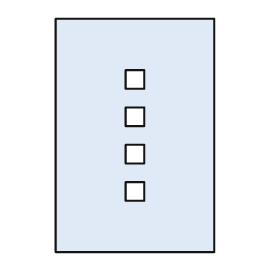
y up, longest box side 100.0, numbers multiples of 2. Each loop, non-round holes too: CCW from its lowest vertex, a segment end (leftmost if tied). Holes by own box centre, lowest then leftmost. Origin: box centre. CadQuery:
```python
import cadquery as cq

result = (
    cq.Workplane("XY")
    .moveTo(-34.0, -50.0)
    .lineTo(34.0, -50.0)
    .lineTo(34.0, 50.0)
    .lineTo(-34.0, 50.0)
    .close()
    .moveTo(-4.0, -28.0)
    .lineTo(4.0, -28.0)
    .lineTo(4.0, -20.0)
    .lineTo(-4.0, -20.0)
    .close()
    .moveTo(-4.0, -12.0)
    .lineTo(4.0, -12.0)
    .lineTo(4.0, -4.0)
    .lineTo(-4.0, -4.0)
    .close()
    .moveTo(-4.0, 4.0)
    .lineTo(4.0, 4.0)
    .lineTo(4.0, 12.0)
    .lineTo(-4.0, 12.0)
    .close()
    .moveTo(-4.0, 20.0)
    .lineTo(4.0, 20.0)
    .lineTo(4.0, 28.0)
    .lineTo(-4.0, 28.0)
    .close()
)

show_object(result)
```